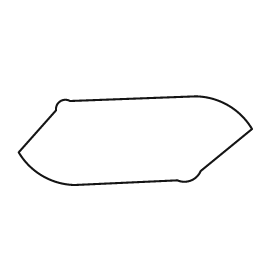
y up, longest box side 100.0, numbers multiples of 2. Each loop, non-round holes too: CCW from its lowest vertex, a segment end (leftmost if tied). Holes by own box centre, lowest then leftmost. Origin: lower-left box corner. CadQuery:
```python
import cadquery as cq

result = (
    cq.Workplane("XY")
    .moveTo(24.0, 0.0)
    .lineTo(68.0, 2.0)
    .threePointArc((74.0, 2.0), (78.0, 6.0))
    .lineTo(100.0, 24.0)
    .threePointArc((90.0, 34.0), (76.0, 38.0))
    .lineTo(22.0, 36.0)
    .threePointArc((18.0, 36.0), (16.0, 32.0))
    .lineTo(0.0, 14.0)
    .threePointArc((10.0, 4.0), (24.0, 0.0))
    .close()
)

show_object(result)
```